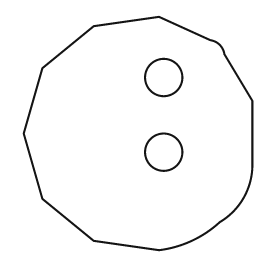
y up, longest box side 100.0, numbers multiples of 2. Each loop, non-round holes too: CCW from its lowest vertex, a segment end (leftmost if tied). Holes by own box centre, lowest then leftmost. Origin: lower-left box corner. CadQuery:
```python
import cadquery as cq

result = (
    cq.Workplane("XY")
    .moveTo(58.0, 0.0)
    .threePointArc((72.0, 4.0), (84.0, 12.0))
    .threePointArc((94.0, 22.0), (98.0, 36.0))
    .lineTo(98.0, 64.0)
    .lineTo(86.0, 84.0)
    .threePointArc((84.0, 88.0), (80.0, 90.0))
    .lineTo(58.0, 100.0)
    .lineTo(30.0, 96.0)
    .lineTo(8.0, 78.0)
    .lineTo(0.0, 50.0)
    .lineTo(8.0, 22.0)
    .lineTo(30.0, 4.0)
    .close()
    .moveTo(60.0, 42.0)
    .circle(8.0)
    .moveTo(60.0, 74.0)
    .circle(8.0)
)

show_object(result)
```